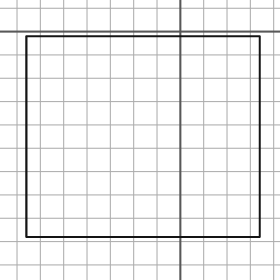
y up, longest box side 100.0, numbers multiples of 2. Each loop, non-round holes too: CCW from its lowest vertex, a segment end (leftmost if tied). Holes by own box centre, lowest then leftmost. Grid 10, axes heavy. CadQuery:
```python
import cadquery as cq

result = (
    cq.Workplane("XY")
    .moveTo(-66.0, -88.0)
    .lineTo(34.0, -88.0)
    .lineTo(34.0, -2.0)
    .lineTo(-66.0, -2.0)
    .close()
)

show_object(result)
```